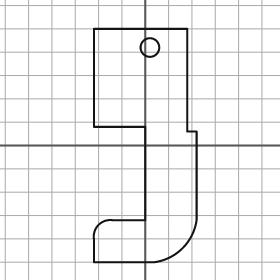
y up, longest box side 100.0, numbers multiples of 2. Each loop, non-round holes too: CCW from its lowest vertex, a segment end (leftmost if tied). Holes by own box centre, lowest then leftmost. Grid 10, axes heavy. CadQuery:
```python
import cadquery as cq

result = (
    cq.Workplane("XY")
    .moveTo(-22.0, -50.0)
    .lineTo(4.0, -50.0)
    .threePointArc((16.0, -44.0), (22.0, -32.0))
    .lineTo(22.0, 6.0)
    .lineTo(18.0, 6.0)
    .lineTo(18.0, 50.0)
    .lineTo(-22.0, 50.0)
    .lineTo(-22.0, 8.0)
    .lineTo(0.0, 8.0)
    .lineTo(0.0, -32.0)
    .lineTo(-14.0, -32.0)
    .threePointArc((-20.0, -34.0), (-22.0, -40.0))
    .close()
    .moveTo(2.0, 42.0)
    .circle(4.0)
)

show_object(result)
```